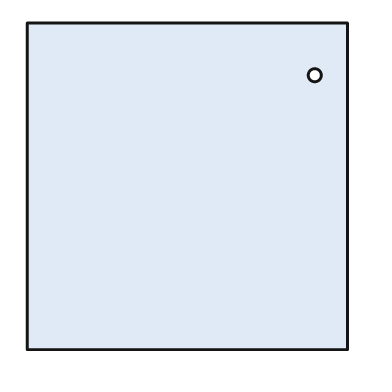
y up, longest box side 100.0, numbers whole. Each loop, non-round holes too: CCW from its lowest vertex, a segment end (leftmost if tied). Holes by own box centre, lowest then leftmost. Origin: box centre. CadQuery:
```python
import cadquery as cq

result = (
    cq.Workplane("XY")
    .moveTo(-49.0, -50.0)
    .lineTo(49.0, -50.0)
    .lineTo(49.0, 50.0)
    .lineTo(-49.0, 50.0)
    .close()
    .moveTo(39.0, 34.0)
    .circle(2.0)
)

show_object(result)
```